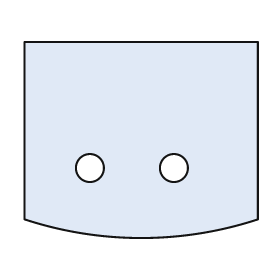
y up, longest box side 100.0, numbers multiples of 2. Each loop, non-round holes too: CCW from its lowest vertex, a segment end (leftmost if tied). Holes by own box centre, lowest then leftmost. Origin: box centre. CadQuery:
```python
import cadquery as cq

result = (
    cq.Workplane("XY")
    .moveTo(-50.0, -34.0)
    .threePointArc((0.0, -42.0), (50.0, -34.0))
    .lineTo(50.0, 42.0)
    .lineTo(-50.0, 42.0)
    .close()
    .moveTo(-22.0, -12.0)
    .circle(6.0)
    .moveTo(14.0, -12.0)
    .circle(6.0)
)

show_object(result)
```